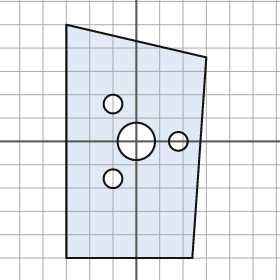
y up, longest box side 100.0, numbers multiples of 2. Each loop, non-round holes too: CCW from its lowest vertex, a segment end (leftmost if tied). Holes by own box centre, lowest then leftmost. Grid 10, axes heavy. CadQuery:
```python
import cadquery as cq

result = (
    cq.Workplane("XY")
    .moveTo(-30.0, -50.0)
    .lineTo(24.0, -50.0)
    .lineTo(30.0, 36.0)
    .lineTo(-30.0, 50.0)
    .close()
    .moveTo(-10.0, -16.0)
    .circle(4.0)
    .moveTo(0.0, 0.0)
    .circle(8.0)
    .moveTo(18.0, 0.0)
    .circle(4.0)
    .moveTo(-10.0, 16.0)
    .circle(4.0)
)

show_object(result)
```